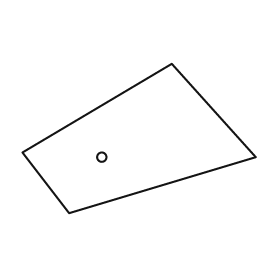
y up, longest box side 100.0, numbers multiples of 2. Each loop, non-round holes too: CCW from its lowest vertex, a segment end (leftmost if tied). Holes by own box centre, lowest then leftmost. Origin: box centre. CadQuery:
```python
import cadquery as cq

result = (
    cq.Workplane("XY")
    .moveTo(-30.0, -32.0)
    .lineTo(50.0, -8.0)
    .lineTo(14.0, 32.0)
    .lineTo(-50.0, -6.0)
    .close()
    .moveTo(-16.0, -8.0)
    .circle(2.0)
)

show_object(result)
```